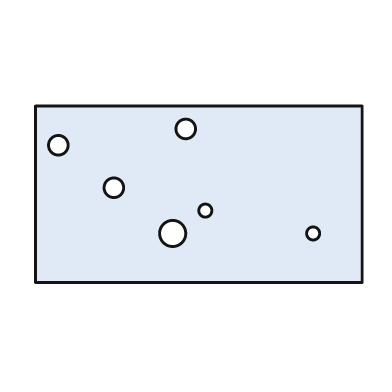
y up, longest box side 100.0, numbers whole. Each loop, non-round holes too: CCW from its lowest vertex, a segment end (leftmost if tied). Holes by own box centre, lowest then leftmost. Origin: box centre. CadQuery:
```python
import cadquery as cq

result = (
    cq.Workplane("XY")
    .moveTo(-50.0, -27.0)
    .lineTo(50.0, -27.0)
    .lineTo(50.0, 27.0)
    .lineTo(-50.0, 27.0)
    .close()
    .moveTo(-8.0, -12.0)
    .circle(4.0)
    .moveTo(35.0, -12.0)
    .circle(2.0)
    .moveTo(2.0, -5.0)
    .circle(2.0)
    .moveTo(-26.0, 2.0)
    .circle(3.0)
    .moveTo(-43.0, 15.0)
    .circle(3.0)
    .moveTo(-4.0, 20.0)
    .circle(3.0)
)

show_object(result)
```